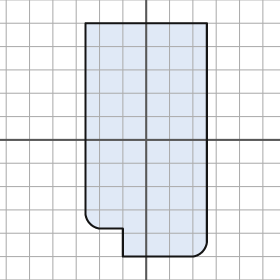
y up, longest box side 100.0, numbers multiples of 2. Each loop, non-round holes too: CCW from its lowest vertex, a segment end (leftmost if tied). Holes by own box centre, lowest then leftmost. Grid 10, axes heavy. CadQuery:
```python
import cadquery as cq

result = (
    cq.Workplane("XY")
    .moveTo(-10.0, -50.0)
    .lineTo(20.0, -50.0)
    .threePointArc((24.0, -48.0), (26.0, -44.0))
    .lineTo(26.0, 50.0)
    .lineTo(-26.0, 50.0)
    .lineTo(-26.0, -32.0)
    .threePointArc((-24.0, -36.0), (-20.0, -38.0))
    .lineTo(-10.0, -38.0)
    .close()
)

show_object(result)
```